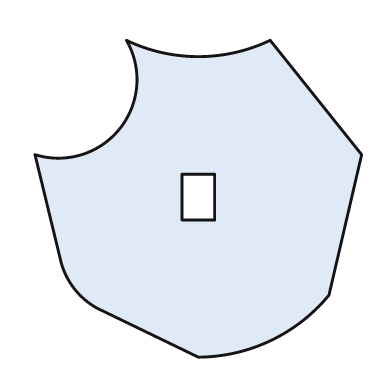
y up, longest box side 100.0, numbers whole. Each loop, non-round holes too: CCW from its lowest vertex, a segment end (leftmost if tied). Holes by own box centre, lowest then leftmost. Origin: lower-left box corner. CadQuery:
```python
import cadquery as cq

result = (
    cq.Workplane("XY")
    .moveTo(50.0, 0.0)
    .threePointArc((72.0, 5.0), (90.0, 19.0))
    .lineTo(100.0, 62.0)
    .lineTo(72.0, 97.0)
    .threePointArc((50.0, 92.0), (28.0, 97.0))
    .threePointArc((26.0, 70.0), (0.0, 62.0))
    .lineTo(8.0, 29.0)
    .threePointArc((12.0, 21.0), (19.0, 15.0))
    .close()
    .moveTo(45.0, 42.0)
    .lineTo(55.0, 42.0)
    .lineTo(55.0, 56.0)
    .lineTo(45.0, 56.0)
    .close()
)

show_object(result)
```